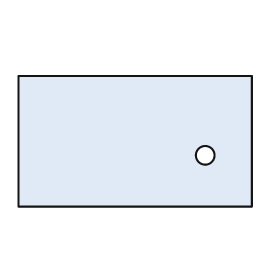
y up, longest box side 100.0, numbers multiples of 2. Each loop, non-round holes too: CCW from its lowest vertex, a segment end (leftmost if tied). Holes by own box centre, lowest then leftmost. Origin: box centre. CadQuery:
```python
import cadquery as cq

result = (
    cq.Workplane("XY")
    .moveTo(-50.0, -28.0)
    .lineTo(50.0, -28.0)
    .lineTo(50.0, 28.0)
    .lineTo(-50.0, 28.0)
    .close()
    .moveTo(30.0, -6.0)
    .circle(4.0)
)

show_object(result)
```